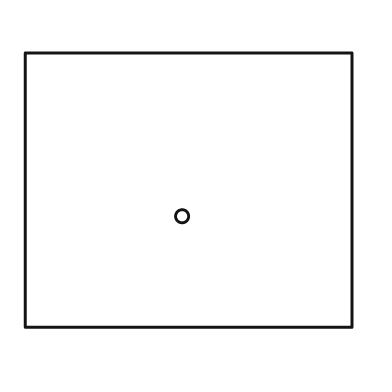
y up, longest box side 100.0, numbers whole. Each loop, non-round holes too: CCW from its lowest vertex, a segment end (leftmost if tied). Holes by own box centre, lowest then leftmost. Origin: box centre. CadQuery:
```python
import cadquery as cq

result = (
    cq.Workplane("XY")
    .moveTo(-50.0, -42.0)
    .lineTo(50.0, -42.0)
    .lineTo(50.0, 42.0)
    .lineTo(-50.0, 42.0)
    .close()
    .moveTo(-2.0, -8.0)
    .circle(2.0)
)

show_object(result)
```